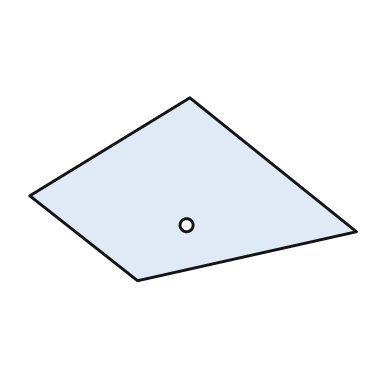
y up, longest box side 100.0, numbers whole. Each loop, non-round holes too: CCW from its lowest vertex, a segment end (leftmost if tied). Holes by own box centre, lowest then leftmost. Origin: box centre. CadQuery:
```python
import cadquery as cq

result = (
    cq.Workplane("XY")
    .moveTo(-17.0, -28.0)
    .lineTo(50.0, -13.0)
    .lineTo(-1.0, 28.0)
    .lineTo(-50.0, -2.0)
    .close()
    .moveTo(-2.0, -11.0)
    .circle(2.0)
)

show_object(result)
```